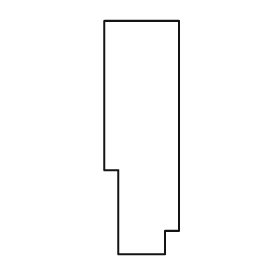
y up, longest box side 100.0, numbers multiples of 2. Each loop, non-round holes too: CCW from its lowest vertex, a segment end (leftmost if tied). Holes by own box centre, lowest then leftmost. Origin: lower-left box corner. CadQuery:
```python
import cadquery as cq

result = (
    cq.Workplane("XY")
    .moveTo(6.0, 0.0)
    .lineTo(26.0, 0.0)
    .lineTo(26.0, 10.0)
    .lineTo(32.0, 10.0)
    .lineTo(32.0, 100.0)
    .lineTo(0.0, 100.0)
    .lineTo(0.0, 36.0)
    .lineTo(6.0, 36.0)
    .close()
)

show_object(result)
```